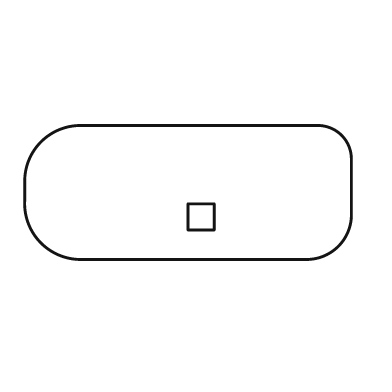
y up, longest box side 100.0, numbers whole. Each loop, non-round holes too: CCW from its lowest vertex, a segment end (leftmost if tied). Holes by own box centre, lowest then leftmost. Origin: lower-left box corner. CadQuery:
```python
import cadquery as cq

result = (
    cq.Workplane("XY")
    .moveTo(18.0, 0.0)
    .lineTo(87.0, 0.0)
    .threePointArc((96.0, 4.0), (100.0, 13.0))
    .lineTo(100.0, 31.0)
    .threePointArc((97.0, 38.0), (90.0, 41.0))
    .lineTo(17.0, 41.0)
    .threePointArc((5.0, 36.0), (0.0, 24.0))
    .lineTo(0.0, 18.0)
    .threePointArc((5.0, 5.0), (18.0, 0.0))
    .close()
    .moveTo(50.0, 9.0)
    .lineTo(58.0, 9.0)
    .lineTo(58.0, 17.0)
    .lineTo(50.0, 17.0)
    .close()
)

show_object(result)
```